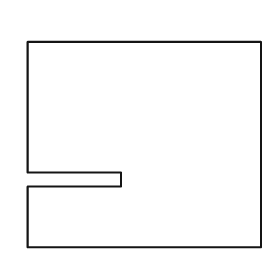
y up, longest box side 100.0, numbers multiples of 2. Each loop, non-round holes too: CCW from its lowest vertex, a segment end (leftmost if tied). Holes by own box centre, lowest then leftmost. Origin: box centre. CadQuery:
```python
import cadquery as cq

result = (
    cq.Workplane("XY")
    .moveTo(-50.0, -44.0)
    .lineTo(50.0, -44.0)
    .lineTo(50.0, 44.0)
    .lineTo(-50.0, 44.0)
    .lineTo(-50.0, -12.0)
    .lineTo(-10.0, -12.0)
    .lineTo(-10.0, -18.0)
    .lineTo(-50.0, -18.0)
    .close()
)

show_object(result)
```